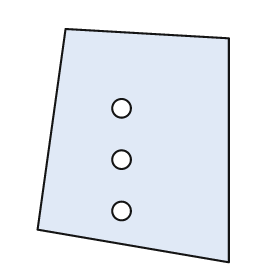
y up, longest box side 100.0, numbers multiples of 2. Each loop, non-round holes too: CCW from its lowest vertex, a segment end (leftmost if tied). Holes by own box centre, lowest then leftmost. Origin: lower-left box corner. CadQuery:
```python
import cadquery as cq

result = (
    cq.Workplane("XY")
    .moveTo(82.0, 0.0)
    .lineTo(82.0, 96.0)
    .lineTo(12.0, 100.0)
    .lineTo(0.0, 14.0)
    .close()
    .moveTo(36.0, 22.0)
    .circle(4.0)
    .moveTo(36.0, 44.0)
    .circle(4.0)
    .moveTo(36.0, 66.0)
    .circle(4.0)
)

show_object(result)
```